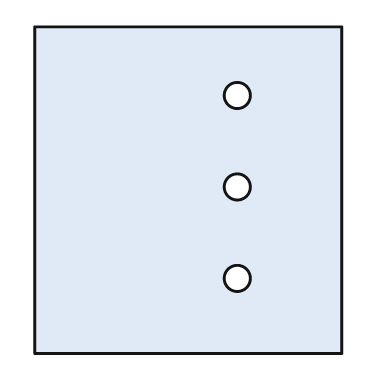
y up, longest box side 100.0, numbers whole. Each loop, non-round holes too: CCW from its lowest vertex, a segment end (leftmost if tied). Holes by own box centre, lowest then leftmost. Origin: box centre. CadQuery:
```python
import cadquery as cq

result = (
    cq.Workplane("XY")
    .moveTo(-47.0, -50.0)
    .lineTo(47.0, -50.0)
    .lineTo(47.0, 50.0)
    .lineTo(-47.0, 50.0)
    .close()
    .moveTo(15.0, -27.0)
    .circle(4.0)
    .moveTo(15.0, 1.0)
    .circle(4.0)
    .moveTo(15.0, 29.0)
    .circle(4.0)
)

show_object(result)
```